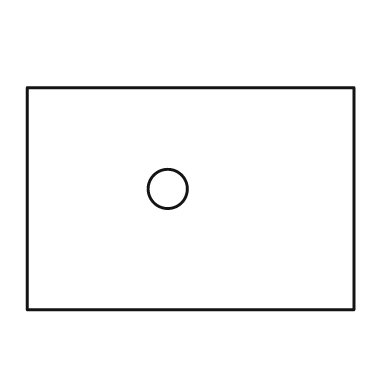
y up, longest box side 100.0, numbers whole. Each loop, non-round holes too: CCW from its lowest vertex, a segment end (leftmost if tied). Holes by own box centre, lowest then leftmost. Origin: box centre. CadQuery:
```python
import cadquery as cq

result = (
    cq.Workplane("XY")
    .moveTo(-50.0, -34.0)
    .lineTo(50.0, -34.0)
    .lineTo(50.0, 34.0)
    .lineTo(-50.0, 34.0)
    .close()
    .moveTo(-7.0, 3.0)
    .circle(6.0)
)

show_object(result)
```